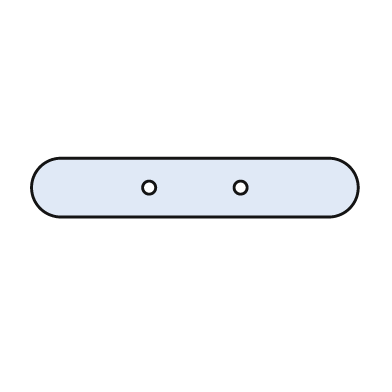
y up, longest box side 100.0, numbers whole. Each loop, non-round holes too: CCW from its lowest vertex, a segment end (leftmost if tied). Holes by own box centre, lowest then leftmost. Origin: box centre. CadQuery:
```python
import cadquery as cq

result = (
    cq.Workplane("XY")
    .moveTo(-41.0, -9.0)
    .lineTo(41.0, -9.0)
    .threePointArc((50.0, 0.0), (41.0, 9.0))
    .lineTo(-41.0, 9.0)
    .threePointArc((-50.0, 0.0), (-41.0, -9.0))
    .close()
    .moveTo(-14.0, 0.0)
    .circle(2.0)
    .moveTo(14.0, 0.0)
    .circle(2.0)
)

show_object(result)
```